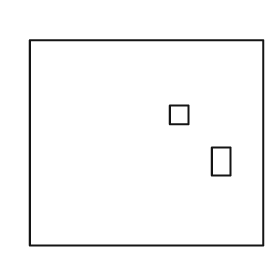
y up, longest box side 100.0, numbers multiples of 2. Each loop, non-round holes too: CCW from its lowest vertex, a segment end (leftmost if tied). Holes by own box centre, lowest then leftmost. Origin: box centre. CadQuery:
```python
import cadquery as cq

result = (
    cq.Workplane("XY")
    .moveTo(-50.0, -44.0)
    .lineTo(50.0, -44.0)
    .lineTo(50.0, 44.0)
    .lineTo(-50.0, 44.0)
    .close()
    .moveTo(28.0, -14.0)
    .lineTo(36.0, -14.0)
    .lineTo(36.0, -2.0)
    .lineTo(28.0, -2.0)
    .close()
    .moveTo(10.0, 8.0)
    .lineTo(18.0, 8.0)
    .lineTo(18.0, 16.0)
    .lineTo(10.0, 16.0)
    .close()
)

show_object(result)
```